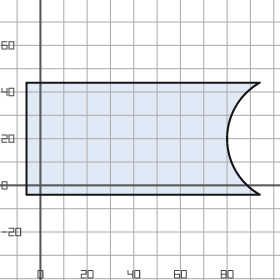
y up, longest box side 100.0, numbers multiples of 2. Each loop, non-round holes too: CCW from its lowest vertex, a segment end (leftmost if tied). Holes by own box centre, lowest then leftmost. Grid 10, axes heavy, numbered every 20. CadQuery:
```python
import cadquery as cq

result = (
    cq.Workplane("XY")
    .moveTo(-6.0, -4.0)
    .lineTo(94.0, -4.0)
    .threePointArc((80.0, 20.0), (94.0, 44.0))
    .lineTo(-6.0, 44.0)
    .close()
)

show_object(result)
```